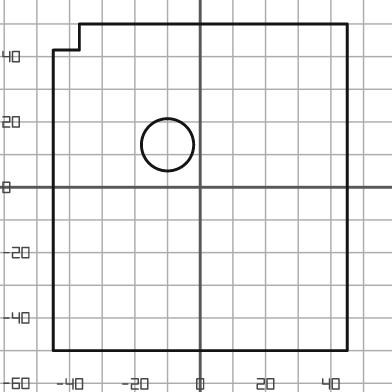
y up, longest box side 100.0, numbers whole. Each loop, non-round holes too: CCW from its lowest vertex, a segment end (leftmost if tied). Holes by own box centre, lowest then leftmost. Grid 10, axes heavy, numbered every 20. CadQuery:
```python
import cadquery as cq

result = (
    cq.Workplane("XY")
    .moveTo(-45.0, -50.0)
    .lineTo(45.0, -50.0)
    .lineTo(45.0, 50.0)
    .lineTo(-37.0, 50.0)
    .lineTo(-37.0, 42.0)
    .lineTo(-45.0, 42.0)
    .close()
    .moveTo(-10.0, 13.0)
    .circle(8.0)
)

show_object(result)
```